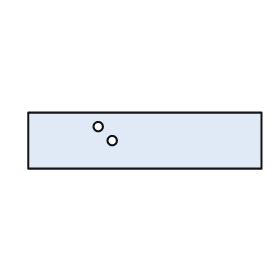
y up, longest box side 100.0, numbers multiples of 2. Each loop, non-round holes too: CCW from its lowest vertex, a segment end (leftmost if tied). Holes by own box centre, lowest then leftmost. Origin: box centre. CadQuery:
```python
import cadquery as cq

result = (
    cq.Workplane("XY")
    .moveTo(-50.0, -12.0)
    .lineTo(50.0, -12.0)
    .lineTo(50.0, 12.0)
    .lineTo(-50.0, 12.0)
    .close()
    .moveTo(-14.0, 0.0)
    .circle(2.0)
    .moveTo(-20.0, 6.0)
    .circle(2.0)
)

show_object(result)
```